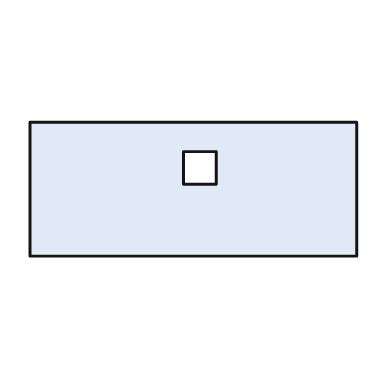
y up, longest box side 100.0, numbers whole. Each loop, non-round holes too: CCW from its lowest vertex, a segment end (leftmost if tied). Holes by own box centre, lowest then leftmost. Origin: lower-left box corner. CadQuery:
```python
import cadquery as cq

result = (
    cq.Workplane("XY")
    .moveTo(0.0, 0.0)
    .lineTo(100.0, 0.0)
    .lineTo(100.0, 41.0)
    .lineTo(0.0, 41.0)
    .close()
    .moveTo(47.0, 22.0)
    .lineTo(57.0, 22.0)
    .lineTo(57.0, 32.0)
    .lineTo(47.0, 32.0)
    .close()
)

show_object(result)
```